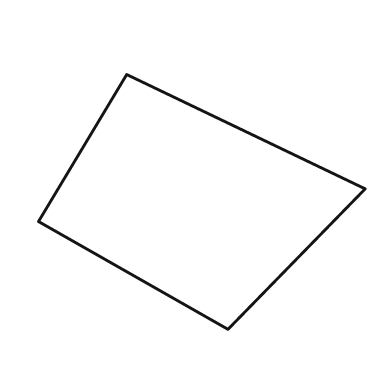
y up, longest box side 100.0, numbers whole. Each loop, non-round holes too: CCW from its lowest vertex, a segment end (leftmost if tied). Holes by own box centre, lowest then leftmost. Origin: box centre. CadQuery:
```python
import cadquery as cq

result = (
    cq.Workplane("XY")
    .moveTo(8.0, -39.0)
    .lineTo(50.0, 4.0)
    .lineTo(-23.0, 39.0)
    .lineTo(-50.0, -6.0)
    .close()
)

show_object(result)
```